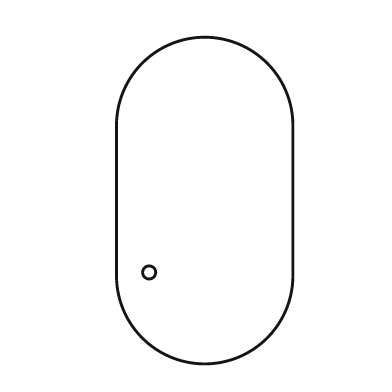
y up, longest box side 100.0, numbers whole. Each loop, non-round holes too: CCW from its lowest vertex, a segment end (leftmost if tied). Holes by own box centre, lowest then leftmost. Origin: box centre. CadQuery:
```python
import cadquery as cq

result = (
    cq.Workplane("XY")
    .moveTo(-27.0, -23.0)
    .threePointArc((0.0, -50.0), (27.0, -23.0))
    .lineTo(27.0, 23.0)
    .threePointArc((0.0, 50.0), (-27.0, 23.0))
    .close()
    .moveTo(-17.0, -22.0)
    .circle(2.0)
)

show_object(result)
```